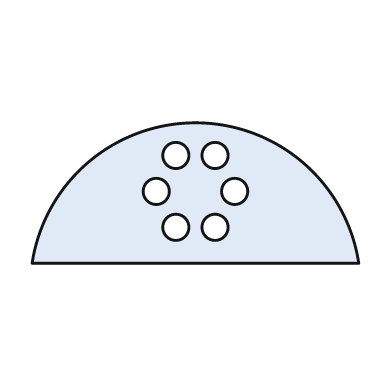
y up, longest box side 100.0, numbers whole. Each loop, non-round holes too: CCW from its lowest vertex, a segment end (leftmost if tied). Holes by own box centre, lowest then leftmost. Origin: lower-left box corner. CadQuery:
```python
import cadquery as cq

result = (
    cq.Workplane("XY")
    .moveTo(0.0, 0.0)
    .lineTo(100.0, 0.0)
    .threePointArc((50.0, 43.0), (0.0, 0.0))
    .close()
    .moveTo(44.0, 11.0)
    .circle(4.0)
    .moveTo(56.0, 11.0)
    .circle(4.0)
    .moveTo(38.0, 22.0)
    .circle(4.0)
    .moveTo(62.0, 22.0)
    .circle(4.0)
    .moveTo(44.0, 33.0)
    .circle(4.0)
    .moveTo(56.0, 33.0)
    .circle(4.0)
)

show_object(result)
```